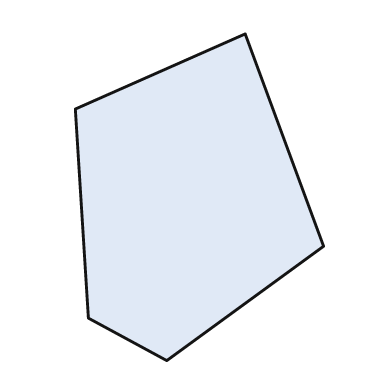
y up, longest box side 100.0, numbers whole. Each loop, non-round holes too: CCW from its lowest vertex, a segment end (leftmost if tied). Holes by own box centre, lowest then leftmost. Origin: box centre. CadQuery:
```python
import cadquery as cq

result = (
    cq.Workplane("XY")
    .moveTo(-10.0, -50.0)
    .lineTo(38.0, -15.0)
    .lineTo(14.0, 50.0)
    .lineTo(-38.0, 27.0)
    .lineTo(-34.0, -37.0)
    .close()
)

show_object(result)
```